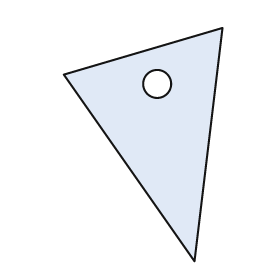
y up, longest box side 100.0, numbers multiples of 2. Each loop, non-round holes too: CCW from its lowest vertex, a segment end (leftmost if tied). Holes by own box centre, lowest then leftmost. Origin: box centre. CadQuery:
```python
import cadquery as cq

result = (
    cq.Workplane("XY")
    .moveTo(22.0, -50.0)
    .lineTo(34.0, 50.0)
    .lineTo(-34.0, 30.0)
    .close()
    .moveTo(6.0, 26.0)
    .circle(6.0)
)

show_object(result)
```